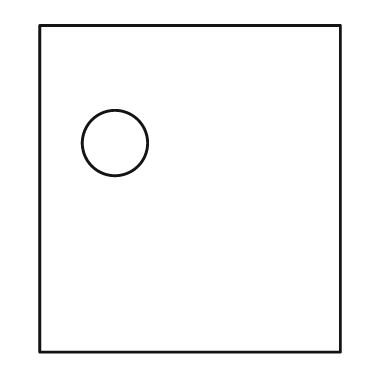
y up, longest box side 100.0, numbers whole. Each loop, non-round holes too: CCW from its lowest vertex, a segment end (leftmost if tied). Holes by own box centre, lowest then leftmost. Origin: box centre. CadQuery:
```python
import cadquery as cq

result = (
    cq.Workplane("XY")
    .moveTo(-46.0, -50.0)
    .lineTo(46.0, -50.0)
    .lineTo(46.0, 50.0)
    .lineTo(-46.0, 50.0)
    .close()
    .moveTo(-23.0, 14.0)
    .circle(10.0)
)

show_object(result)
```